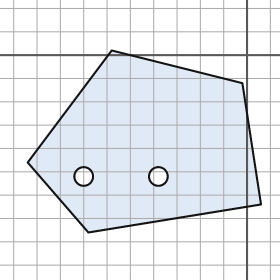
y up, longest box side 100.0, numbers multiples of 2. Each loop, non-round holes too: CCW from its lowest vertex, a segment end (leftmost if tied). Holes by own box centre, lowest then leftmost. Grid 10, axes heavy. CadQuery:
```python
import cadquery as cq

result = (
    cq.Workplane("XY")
    .moveTo(-68.0, -76.0)
    .lineTo(6.0, -64.0)
    .lineTo(-2.0, -12.0)
    .lineTo(-58.0, 2.0)
    .lineTo(-94.0, -46.0)
    .close()
    .moveTo(-70.0, -52.0)
    .circle(4.0)
    .moveTo(-38.0, -52.0)
    .circle(4.0)
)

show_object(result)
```